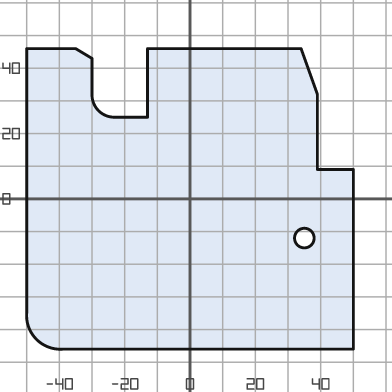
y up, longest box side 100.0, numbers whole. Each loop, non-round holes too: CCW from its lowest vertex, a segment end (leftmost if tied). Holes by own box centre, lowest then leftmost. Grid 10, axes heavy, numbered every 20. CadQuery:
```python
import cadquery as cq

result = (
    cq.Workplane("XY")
    .moveTo(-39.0, -46.0)
    .lineTo(50.0, -46.0)
    .lineTo(50.0, 9.0)
    .lineTo(39.0, 9.0)
    .lineTo(39.0, 32.0)
    .lineTo(34.0, 46.0)
    .lineTo(-13.0, 46.0)
    .lineTo(-13.0, 25.0)
    .lineTo(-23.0, 25.0)
    .threePointArc((-28.0, 27.0), (-30.0, 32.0))
    .lineTo(-30.0, 43.0)
    .lineTo(-35.0, 46.0)
    .lineTo(-50.0, 46.0)
    .lineTo(-50.0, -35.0)
    .threePointArc((-47.0, -43.0), (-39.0, -46.0))
    .close()
    .moveTo(35.0, -12.0)
    .circle(3.0)
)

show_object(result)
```